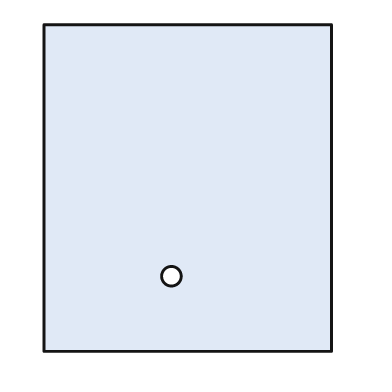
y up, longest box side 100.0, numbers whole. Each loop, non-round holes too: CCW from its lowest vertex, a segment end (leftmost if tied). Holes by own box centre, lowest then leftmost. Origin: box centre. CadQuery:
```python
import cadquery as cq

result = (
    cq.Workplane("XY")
    .moveTo(-44.0, -50.0)
    .lineTo(44.0, -50.0)
    .lineTo(44.0, 50.0)
    .lineTo(-44.0, 50.0)
    .close()
    .moveTo(-5.0, -27.0)
    .circle(3.0)
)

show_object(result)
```